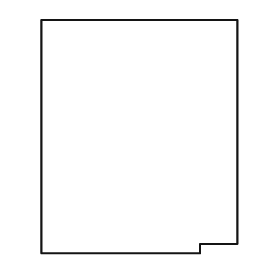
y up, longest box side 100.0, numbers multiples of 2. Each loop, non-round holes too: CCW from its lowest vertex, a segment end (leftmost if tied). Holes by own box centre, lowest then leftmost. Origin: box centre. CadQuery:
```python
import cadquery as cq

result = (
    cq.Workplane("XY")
    .moveTo(-42.0, -50.0)
    .lineTo(26.0, -50.0)
    .lineTo(26.0, -46.0)
    .lineTo(42.0, -46.0)
    .lineTo(42.0, 50.0)
    .lineTo(-42.0, 50.0)
    .close()
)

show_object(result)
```